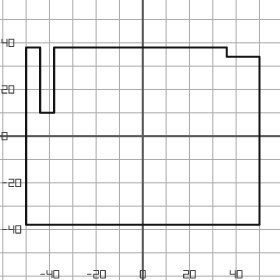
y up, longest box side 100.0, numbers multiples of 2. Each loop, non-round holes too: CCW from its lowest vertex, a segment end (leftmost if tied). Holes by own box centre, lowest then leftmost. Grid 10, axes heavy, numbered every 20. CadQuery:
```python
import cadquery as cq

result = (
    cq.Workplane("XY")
    .moveTo(-50.0, -38.0)
    .lineTo(50.0, -38.0)
    .lineTo(50.0, 34.0)
    .lineTo(36.0, 34.0)
    .lineTo(36.0, 38.0)
    .lineTo(-38.0, 38.0)
    .lineTo(-38.0, 10.0)
    .lineTo(-44.0, 10.0)
    .lineTo(-44.0, 38.0)
    .lineTo(-50.0, 38.0)
    .close()
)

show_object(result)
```